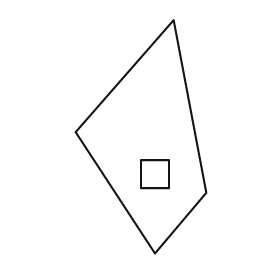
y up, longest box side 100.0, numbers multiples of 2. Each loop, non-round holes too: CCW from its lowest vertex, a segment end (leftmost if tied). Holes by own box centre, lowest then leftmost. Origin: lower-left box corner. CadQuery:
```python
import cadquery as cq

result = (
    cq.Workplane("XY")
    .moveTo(34.0, 0.0)
    .lineTo(56.0, 26.0)
    .lineTo(42.0, 100.0)
    .lineTo(0.0, 52.0)
    .close()
    .moveTo(28.0, 28.0)
    .lineTo(40.0, 28.0)
    .lineTo(40.0, 40.0)
    .lineTo(28.0, 40.0)
    .close()
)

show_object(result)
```